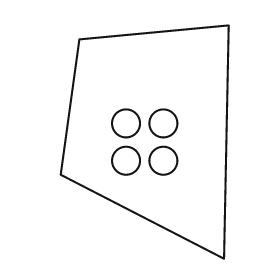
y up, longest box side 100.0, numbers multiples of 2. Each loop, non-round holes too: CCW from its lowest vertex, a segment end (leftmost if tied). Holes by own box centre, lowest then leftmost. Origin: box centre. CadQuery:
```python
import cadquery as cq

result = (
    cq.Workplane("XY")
    .moveTo(34.0, -50.0)
    .lineTo(36.0, 50.0)
    .lineTo(-28.0, 44.0)
    .lineTo(-36.0, -14.0)
    .close()
    .moveTo(-8.0, -8.0)
    .circle(6.0)
    .moveTo(8.0, -8.0)
    .circle(6.0)
    .moveTo(-8.0, 8.0)
    .circle(6.0)
    .moveTo(8.0, 8.0)
    .circle(6.0)
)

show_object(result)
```